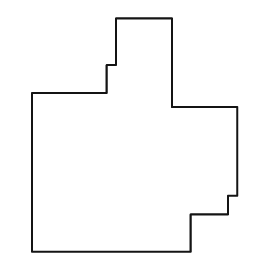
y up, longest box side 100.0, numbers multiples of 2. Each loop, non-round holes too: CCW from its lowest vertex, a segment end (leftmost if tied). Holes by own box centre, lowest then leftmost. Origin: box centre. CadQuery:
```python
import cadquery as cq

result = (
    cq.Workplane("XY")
    .moveTo(-44.0, -50.0)
    .lineTo(24.0, -50.0)
    .lineTo(24.0, -34.0)
    .lineTo(40.0, -34.0)
    .lineTo(40.0, -26.0)
    .lineTo(44.0, -26.0)
    .lineTo(44.0, 12.0)
    .lineTo(16.0, 12.0)
    .lineTo(16.0, 50.0)
    .lineTo(-8.0, 50.0)
    .lineTo(-8.0, 30.0)
    .lineTo(-12.0, 30.0)
    .lineTo(-12.0, 18.0)
    .lineTo(-44.0, 18.0)
    .close()
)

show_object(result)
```